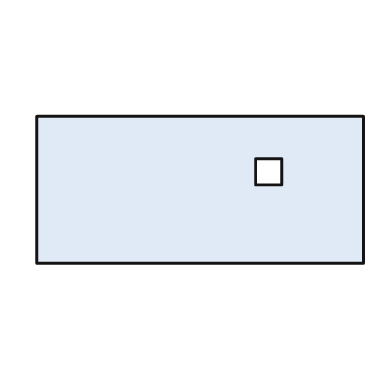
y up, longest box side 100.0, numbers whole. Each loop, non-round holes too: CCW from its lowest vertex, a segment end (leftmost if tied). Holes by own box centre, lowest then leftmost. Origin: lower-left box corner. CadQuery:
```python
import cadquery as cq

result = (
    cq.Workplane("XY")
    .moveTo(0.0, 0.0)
    .lineTo(100.0, 0.0)
    .lineTo(100.0, 45.0)
    .lineTo(0.0, 45.0)
    .close()
    .moveTo(67.0, 24.0)
    .lineTo(75.0, 24.0)
    .lineTo(75.0, 32.0)
    .lineTo(67.0, 32.0)
    .close()
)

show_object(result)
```